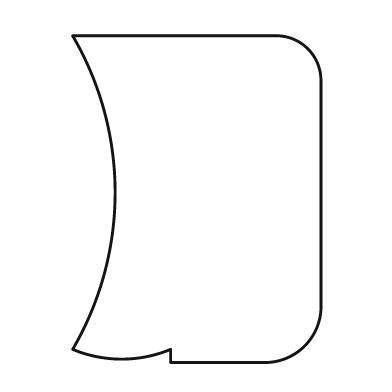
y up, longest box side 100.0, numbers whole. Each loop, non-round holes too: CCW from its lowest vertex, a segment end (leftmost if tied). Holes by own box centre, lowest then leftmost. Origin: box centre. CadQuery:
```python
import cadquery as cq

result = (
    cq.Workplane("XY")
    .moveTo(-8.0, -50.0)
    .lineTo(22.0, -50.0)
    .threePointArc((33.0, -45.0), (38.0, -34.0))
    .lineTo(38.0, 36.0)
    .threePointArc((34.0, 46.0), (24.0, 50.0))
    .lineTo(-38.0, 50.0)
    .threePointArc((-25.0, 2.0), (-38.0, -46.0))
    .threePointArc((-23.0, -49.0), (-8.0, -46.0))
    .close()
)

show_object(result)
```